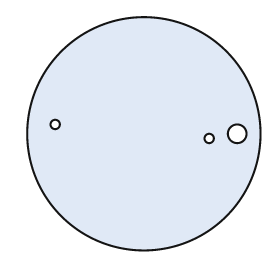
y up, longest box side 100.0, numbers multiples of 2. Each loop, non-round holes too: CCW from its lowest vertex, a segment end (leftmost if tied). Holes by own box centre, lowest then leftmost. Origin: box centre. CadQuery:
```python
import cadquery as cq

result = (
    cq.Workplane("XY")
    .moveTo(0.0, 0.0)
    .circle(50.0)
    .moveTo(28.0, -2.0)
    .circle(2.0)
    .moveTo(40.0, 0.0)
    .circle(4.0)
    .moveTo(-38.0, 4.0)
    .circle(2.0)
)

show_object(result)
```